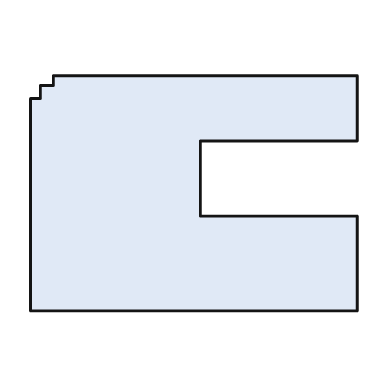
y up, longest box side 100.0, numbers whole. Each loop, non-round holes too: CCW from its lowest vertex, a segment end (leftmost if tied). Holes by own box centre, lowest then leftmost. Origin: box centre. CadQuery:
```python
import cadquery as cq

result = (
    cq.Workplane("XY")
    .moveTo(-50.0, -36.0)
    .lineTo(50.0, -36.0)
    .lineTo(50.0, -7.0)
    .lineTo(2.0, -7.0)
    .lineTo(2.0, 16.0)
    .lineTo(50.0, 16.0)
    .lineTo(50.0, 36.0)
    .lineTo(-43.0, 36.0)
    .lineTo(-43.0, 33.0)
    .lineTo(-47.0, 33.0)
    .lineTo(-47.0, 29.0)
    .lineTo(-50.0, 29.0)
    .close()
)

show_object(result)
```